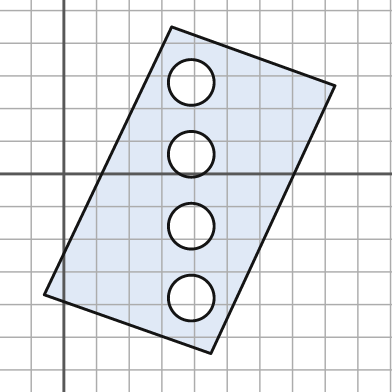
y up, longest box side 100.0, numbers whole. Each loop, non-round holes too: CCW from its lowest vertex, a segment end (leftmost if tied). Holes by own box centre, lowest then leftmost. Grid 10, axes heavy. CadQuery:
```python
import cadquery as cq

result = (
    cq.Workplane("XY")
    .moveTo(45.0, -55.0)
    .lineTo(83.0, 27.0)
    .lineTo(33.0, 45.0)
    .lineTo(-6.0, -37.0)
    .close()
    .moveTo(39.0, -38.0)
    .circle(7.0)
    .moveTo(39.0, -16.0)
    .circle(7.0)
    .moveTo(39.0, 6.0)
    .circle(7.0)
    .moveTo(39.0, 28.0)
    .circle(7.0)
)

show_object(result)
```